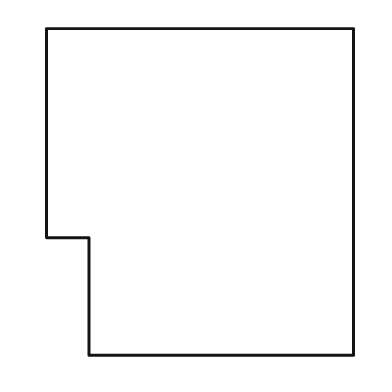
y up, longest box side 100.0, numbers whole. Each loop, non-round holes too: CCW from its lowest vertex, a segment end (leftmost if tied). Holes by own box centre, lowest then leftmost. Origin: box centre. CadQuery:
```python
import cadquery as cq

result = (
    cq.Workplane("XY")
    .moveTo(-34.0, -50.0)
    .lineTo(47.0, -50.0)
    .lineTo(47.0, 50.0)
    .lineTo(-47.0, 50.0)
    .lineTo(-47.0, -14.0)
    .lineTo(-34.0, -14.0)
    .close()
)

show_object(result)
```